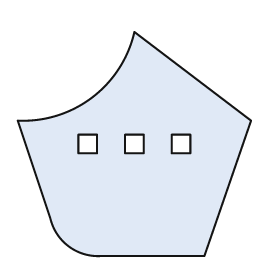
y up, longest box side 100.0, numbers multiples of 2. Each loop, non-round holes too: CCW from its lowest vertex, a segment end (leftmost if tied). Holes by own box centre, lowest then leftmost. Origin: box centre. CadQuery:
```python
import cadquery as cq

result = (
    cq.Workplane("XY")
    .moveTo(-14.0, -48.0)
    .lineTo(30.0, -48.0)
    .lineTo(50.0, 10.0)
    .lineTo(0.0, 48.0)
    .threePointArc((-18.0, 20.0), (-50.0, 10.0))
    .lineTo(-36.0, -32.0)
    .threePointArc((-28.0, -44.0), (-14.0, -48.0))
    .close()
    .moveTo(-24.0, -4.0)
    .lineTo(-16.0, -4.0)
    .lineTo(-16.0, 4.0)
    .lineTo(-24.0, 4.0)
    .close()
    .moveTo(-4.0, -4.0)
    .lineTo(4.0, -4.0)
    .lineTo(4.0, 4.0)
    .lineTo(-4.0, 4.0)
    .close()
    .moveTo(16.0, -4.0)
    .lineTo(24.0, -4.0)
    .lineTo(24.0, 4.0)
    .lineTo(16.0, 4.0)
    .close()
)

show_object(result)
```